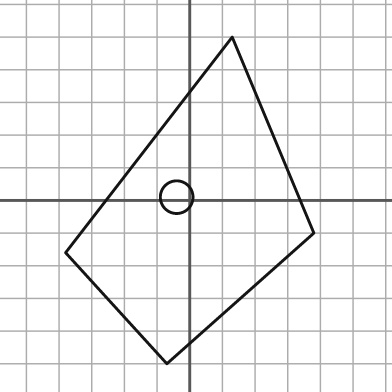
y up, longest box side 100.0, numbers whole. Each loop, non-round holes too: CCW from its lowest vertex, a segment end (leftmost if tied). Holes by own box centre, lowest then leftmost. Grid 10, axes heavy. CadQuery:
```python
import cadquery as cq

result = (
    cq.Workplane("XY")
    .moveTo(-7.0, -50.0)
    .lineTo(38.0, -10.0)
    .lineTo(13.0, 50.0)
    .lineTo(-38.0, -16.0)
    .close()
    .moveTo(-4.0, 1.0)
    .circle(5.0)
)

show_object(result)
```